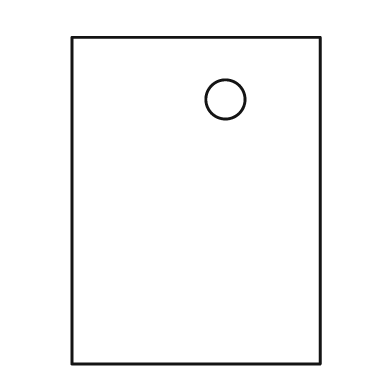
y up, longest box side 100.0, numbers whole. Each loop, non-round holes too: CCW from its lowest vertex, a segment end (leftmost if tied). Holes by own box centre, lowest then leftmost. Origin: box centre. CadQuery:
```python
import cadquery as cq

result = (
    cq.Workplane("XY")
    .moveTo(-38.0, -50.0)
    .lineTo(38.0, -50.0)
    .lineTo(38.0, 50.0)
    .lineTo(-38.0, 50.0)
    .close()
    .moveTo(9.0, 31.0)
    .circle(6.0)
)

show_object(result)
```